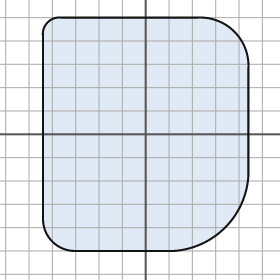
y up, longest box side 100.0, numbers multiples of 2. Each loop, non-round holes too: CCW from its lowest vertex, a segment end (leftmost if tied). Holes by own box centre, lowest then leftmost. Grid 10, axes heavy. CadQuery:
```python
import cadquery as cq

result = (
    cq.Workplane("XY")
    .moveTo(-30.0, -50.0)
    .lineTo(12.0, -50.0)
    .threePointArc((34.0, -40.0), (44.0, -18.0))
    .lineTo(44.0, 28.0)
    .threePointArc((38.0, 44.0), (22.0, 50.0))
    .lineTo(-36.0, 50.0)
    .threePointArc((-42.0, 48.0), (-44.0, 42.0))
    .lineTo(-44.0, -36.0)
    .threePointArc((-40.0, -46.0), (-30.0, -50.0))
    .close()
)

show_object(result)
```